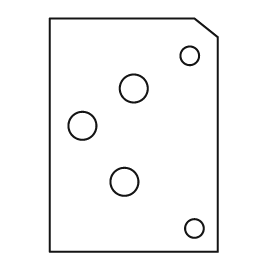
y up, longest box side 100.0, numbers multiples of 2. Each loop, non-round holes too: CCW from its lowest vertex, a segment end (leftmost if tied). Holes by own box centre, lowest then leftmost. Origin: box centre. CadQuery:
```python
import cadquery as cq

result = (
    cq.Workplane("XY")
    .moveTo(-36.0, -50.0)
    .lineTo(36.0, -50.0)
    .lineTo(36.0, 42.0)
    .lineTo(26.0, 50.0)
    .lineTo(-36.0, 50.0)
    .close()
    .moveTo(26.0, -40.0)
    .circle(4.0)
    .moveTo(-4.0, -20.0)
    .circle(6.0)
    .moveTo(-22.0, 4.0)
    .circle(6.0)
    .moveTo(0.0, 20.0)
    .circle(6.0)
    .moveTo(24.0, 34.0)
    .circle(4.0)
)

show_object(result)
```